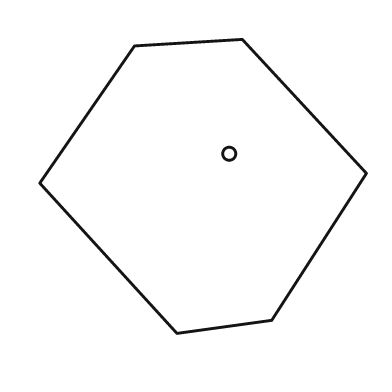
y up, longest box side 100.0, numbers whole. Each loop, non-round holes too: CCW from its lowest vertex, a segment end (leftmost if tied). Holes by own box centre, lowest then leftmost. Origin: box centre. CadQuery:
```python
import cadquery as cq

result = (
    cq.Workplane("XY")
    .moveTo(-8.0, -45.0)
    .lineTo(21.0, -41.0)
    .lineTo(50.0, 4.0)
    .lineTo(12.0, 45.0)
    .lineTo(-21.0, 43.0)
    .lineTo(-50.0, 1.0)
    .close()
    .moveTo(8.0, 10.0)
    .circle(2.0)
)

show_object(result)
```